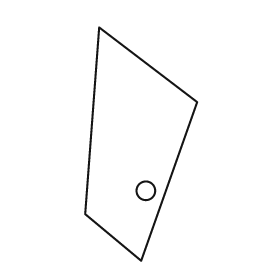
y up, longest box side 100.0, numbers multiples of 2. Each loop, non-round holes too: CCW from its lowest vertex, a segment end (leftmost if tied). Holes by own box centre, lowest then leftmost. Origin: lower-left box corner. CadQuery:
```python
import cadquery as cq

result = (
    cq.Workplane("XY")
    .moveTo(24.0, 0.0)
    .lineTo(48.0, 68.0)
    .lineTo(6.0, 100.0)
    .lineTo(0.0, 20.0)
    .close()
    .moveTo(26.0, 30.0)
    .circle(4.0)
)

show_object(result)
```